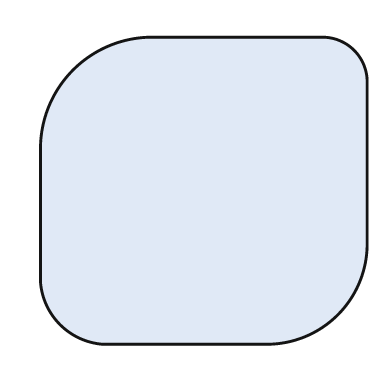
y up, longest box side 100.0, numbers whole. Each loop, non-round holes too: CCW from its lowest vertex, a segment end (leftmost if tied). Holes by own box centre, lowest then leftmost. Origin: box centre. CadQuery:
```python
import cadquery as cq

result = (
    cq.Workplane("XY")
    .moveTo(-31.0, -47.0)
    .lineTo(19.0, -47.0)
    .threePointArc((41.0, -38.0), (50.0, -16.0))
    .lineTo(50.0, 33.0)
    .threePointArc((46.0, 43.0), (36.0, 47.0))
    .lineTo(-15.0, 47.0)
    .threePointArc((-40.0, 37.0), (-50.0, 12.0))
    .lineTo(-50.0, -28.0)
    .threePointArc((-44.0, -41.0), (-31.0, -47.0))
    .close()
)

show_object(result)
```